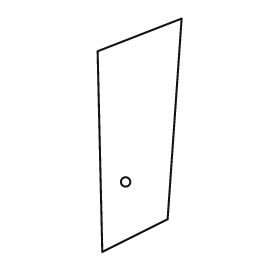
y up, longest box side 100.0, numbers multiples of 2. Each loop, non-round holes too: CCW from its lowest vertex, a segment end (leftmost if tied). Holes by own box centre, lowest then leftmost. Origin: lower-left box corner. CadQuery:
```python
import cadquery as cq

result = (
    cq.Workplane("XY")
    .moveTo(2.0, 0.0)
    .lineTo(30.0, 14.0)
    .lineTo(36.0, 100.0)
    .lineTo(0.0, 86.0)
    .close()
    .moveTo(12.0, 30.0)
    .circle(2.0)
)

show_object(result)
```